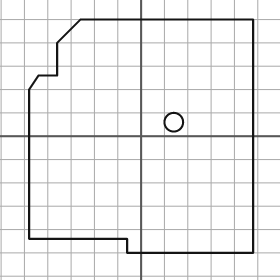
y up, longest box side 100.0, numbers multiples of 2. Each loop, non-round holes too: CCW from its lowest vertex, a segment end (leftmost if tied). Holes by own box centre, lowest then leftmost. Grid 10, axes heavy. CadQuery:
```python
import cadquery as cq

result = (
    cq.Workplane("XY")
    .moveTo(-6.0, -50.0)
    .lineTo(48.0, -50.0)
    .lineTo(48.0, 50.0)
    .lineTo(-26.0, 50.0)
    .lineTo(-36.0, 40.0)
    .lineTo(-36.0, 26.0)
    .lineTo(-44.0, 26.0)
    .lineTo(-48.0, 20.0)
    .lineTo(-48.0, -44.0)
    .lineTo(-6.0, -44.0)
    .close()
    .moveTo(14.0, 6.0)
    .circle(4.0)
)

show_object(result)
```